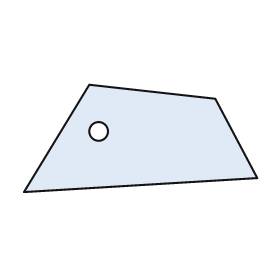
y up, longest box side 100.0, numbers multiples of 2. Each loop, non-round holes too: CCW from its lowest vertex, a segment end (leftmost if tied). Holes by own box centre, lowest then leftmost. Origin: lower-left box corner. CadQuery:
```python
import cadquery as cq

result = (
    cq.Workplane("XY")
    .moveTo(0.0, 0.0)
    .lineTo(100.0, 6.0)
    .lineTo(82.0, 40.0)
    .lineTo(28.0, 46.0)
    .close()
    .moveTo(32.0, 26.0)
    .circle(4.0)
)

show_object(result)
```